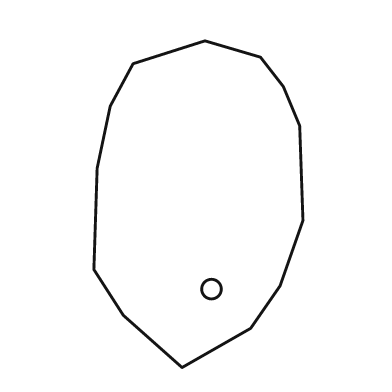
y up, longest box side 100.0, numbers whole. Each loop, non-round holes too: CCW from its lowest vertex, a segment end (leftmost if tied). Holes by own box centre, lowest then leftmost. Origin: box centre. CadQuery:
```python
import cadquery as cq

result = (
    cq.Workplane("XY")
    .moveTo(-5.0, -50.0)
    .lineTo(16.0, -38.0)
    .lineTo(25.0, -25.0)
    .lineTo(32.0, -5.0)
    .lineTo(31.0, 24.0)
    .lineTo(26.0, 36.0)
    .lineTo(19.0, 45.0)
    .lineTo(2.0, 50.0)
    .lineTo(-20.0, 43.0)
    .lineTo(-27.0, 30.0)
    .lineTo(-31.0, 11.0)
    .lineTo(-32.0, -20.0)
    .lineTo(-23.0, -34.0)
    .close()
    .moveTo(4.0, -26.0)
    .circle(3.0)
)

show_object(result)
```